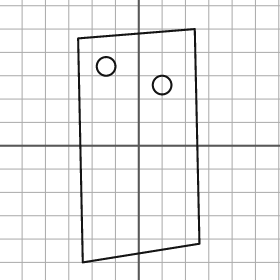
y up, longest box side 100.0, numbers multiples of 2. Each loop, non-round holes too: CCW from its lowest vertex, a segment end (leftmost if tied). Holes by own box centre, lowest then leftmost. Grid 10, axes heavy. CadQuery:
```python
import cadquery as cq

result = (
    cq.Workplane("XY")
    .moveTo(-24.0, -50.0)
    .lineTo(26.0, -42.0)
    .lineTo(24.0, 50.0)
    .lineTo(-26.0, 46.0)
    .close()
    .moveTo(10.0, 26.0)
    .circle(4.0)
    .moveTo(-14.0, 34.0)
    .circle(4.0)
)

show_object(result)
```